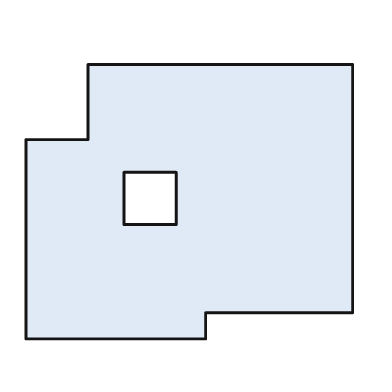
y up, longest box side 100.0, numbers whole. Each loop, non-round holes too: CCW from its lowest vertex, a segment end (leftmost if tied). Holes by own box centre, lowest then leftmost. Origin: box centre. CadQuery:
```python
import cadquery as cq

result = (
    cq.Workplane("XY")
    .moveTo(-50.0, -42.0)
    .lineTo(5.0, -42.0)
    .lineTo(5.0, -34.0)
    .lineTo(50.0, -34.0)
    .lineTo(50.0, 42.0)
    .lineTo(-31.0, 42.0)
    .lineTo(-31.0, 19.0)
    .lineTo(-50.0, 19.0)
    .close()
    .moveTo(-20.0, -7.0)
    .lineTo(-4.0, -7.0)
    .lineTo(-4.0, 9.0)
    .lineTo(-20.0, 9.0)
    .close()
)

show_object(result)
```